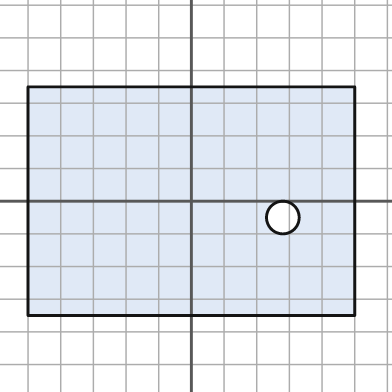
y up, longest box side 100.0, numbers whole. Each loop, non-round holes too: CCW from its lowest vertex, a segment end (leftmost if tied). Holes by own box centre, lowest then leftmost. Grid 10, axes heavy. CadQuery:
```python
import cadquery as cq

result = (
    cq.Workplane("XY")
    .moveTo(-50.0, -35.0)
    .lineTo(50.0, -35.0)
    .lineTo(50.0, 35.0)
    .lineTo(-50.0, 35.0)
    .close()
    .moveTo(28.0, -5.0)
    .circle(5.0)
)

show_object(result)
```